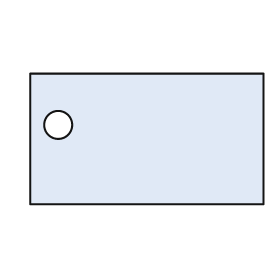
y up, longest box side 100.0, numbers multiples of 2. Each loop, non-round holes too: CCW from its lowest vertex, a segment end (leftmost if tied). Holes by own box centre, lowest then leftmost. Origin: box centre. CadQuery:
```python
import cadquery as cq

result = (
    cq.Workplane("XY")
    .moveTo(-50.0, -28.0)
    .lineTo(50.0, -28.0)
    .lineTo(50.0, 28.0)
    .lineTo(-50.0, 28.0)
    .close()
    .moveTo(-38.0, 6.0)
    .circle(6.0)
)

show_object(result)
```